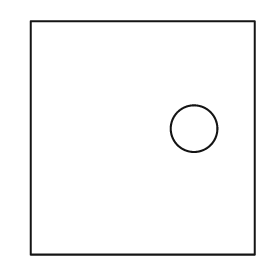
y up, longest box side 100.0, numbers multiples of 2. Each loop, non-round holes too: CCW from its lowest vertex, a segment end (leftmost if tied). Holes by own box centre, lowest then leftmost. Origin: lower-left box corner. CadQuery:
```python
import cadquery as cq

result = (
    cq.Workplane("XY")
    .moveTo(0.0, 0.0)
    .lineTo(96.0, 0.0)
    .lineTo(96.0, 100.0)
    .lineTo(0.0, 100.0)
    .close()
    .moveTo(70.0, 54.0)
    .circle(10.0)
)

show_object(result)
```